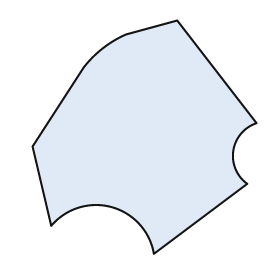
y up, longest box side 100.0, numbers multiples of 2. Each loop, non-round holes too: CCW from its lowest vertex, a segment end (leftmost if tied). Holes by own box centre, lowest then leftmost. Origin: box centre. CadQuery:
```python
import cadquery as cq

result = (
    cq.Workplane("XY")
    .moveTo(4.0, -50.0)
    .lineTo(44.0, -20.0)
    .threePointArc((38.0, -6.0), (48.0, 6.0))
    .lineTo(14.0, 50.0)
    .lineTo(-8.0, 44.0)
    .threePointArc((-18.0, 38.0), (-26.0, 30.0))
    .lineTo(-48.0, -4.0)
    .lineTo(-40.0, -38.0)
    .threePointArc((-14.0, -30.0), (4.0, -50.0))
    .close()
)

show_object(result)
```